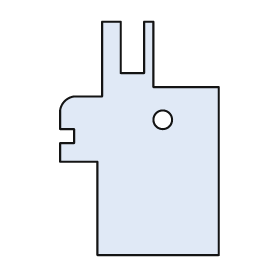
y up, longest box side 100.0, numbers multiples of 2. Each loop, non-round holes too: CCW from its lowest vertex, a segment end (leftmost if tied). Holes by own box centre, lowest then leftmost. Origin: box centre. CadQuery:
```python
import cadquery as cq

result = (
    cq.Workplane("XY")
    .moveTo(-18.0, -50.0)
    .lineTo(34.0, -50.0)
    .lineTo(34.0, 22.0)
    .lineTo(6.0, 22.0)
    .lineTo(6.0, 50.0)
    .lineTo(2.0, 50.0)
    .lineTo(2.0, 28.0)
    .lineTo(-8.0, 28.0)
    .lineTo(-8.0, 50.0)
    .lineTo(-16.0, 50.0)
    .lineTo(-16.0, 18.0)
    .lineTo(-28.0, 18.0)
    .threePointArc((-32.0, 16.0), (-34.0, 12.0))
    .lineTo(-34.0, 4.0)
    .lineTo(-28.0, 4.0)
    .lineTo(-28.0, -2.0)
    .lineTo(-34.0, -2.0)
    .lineTo(-34.0, -10.0)
    .lineTo(-18.0, -10.0)
    .close()
    .moveTo(10.0, 8.0)
    .circle(4.0)
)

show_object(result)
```